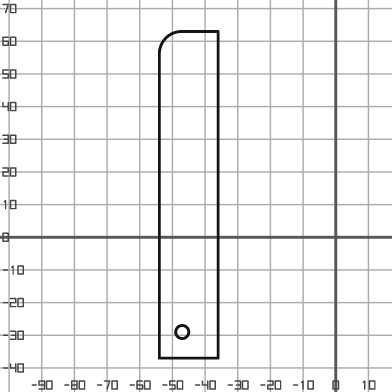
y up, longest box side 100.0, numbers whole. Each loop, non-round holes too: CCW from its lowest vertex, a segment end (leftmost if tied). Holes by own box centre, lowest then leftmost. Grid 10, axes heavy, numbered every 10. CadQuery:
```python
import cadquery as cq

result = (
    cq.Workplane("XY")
    .moveTo(-54.0, -37.0)
    .lineTo(-36.0, -37.0)
    .lineTo(-36.0, 63.0)
    .lineTo(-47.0, 63.0)
    .threePointArc((-52.0, 61.0), (-54.0, 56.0))
    .close()
    .moveTo(-47.0, -29.0)
    .circle(2.0)
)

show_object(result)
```